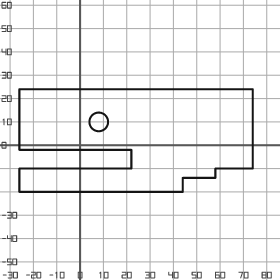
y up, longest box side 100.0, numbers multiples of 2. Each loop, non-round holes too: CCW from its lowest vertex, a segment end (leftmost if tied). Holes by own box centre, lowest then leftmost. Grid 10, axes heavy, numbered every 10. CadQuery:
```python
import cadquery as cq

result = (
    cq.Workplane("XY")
    .moveTo(-26.0, -20.0)
    .lineTo(44.0, -20.0)
    .lineTo(44.0, -14.0)
    .lineTo(58.0, -14.0)
    .lineTo(58.0, -10.0)
    .lineTo(74.0, -10.0)
    .lineTo(74.0, 24.0)
    .lineTo(-26.0, 24.0)
    .lineTo(-26.0, -2.0)
    .lineTo(22.0, -2.0)
    .lineTo(22.0, -10.0)
    .lineTo(-26.0, -10.0)
    .close()
    .moveTo(8.0, 10.0)
    .circle(4.0)
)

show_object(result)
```